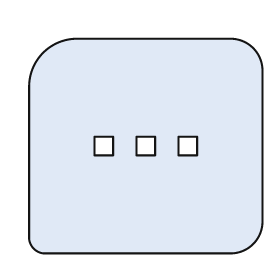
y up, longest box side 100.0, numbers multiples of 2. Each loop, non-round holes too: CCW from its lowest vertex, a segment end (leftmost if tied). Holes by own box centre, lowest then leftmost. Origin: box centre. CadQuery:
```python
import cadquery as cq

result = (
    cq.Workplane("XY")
    .moveTo(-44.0, -46.0)
    .lineTo(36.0, -46.0)
    .threePointArc((46.0, -42.0), (50.0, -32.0))
    .lineTo(50.0, 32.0)
    .threePointArc((46.0, 42.0), (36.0, 46.0))
    .lineTo(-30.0, 46.0)
    .threePointArc((-44.0, 40.0), (-50.0, 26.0))
    .lineTo(-50.0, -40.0)
    .threePointArc((-48.0, -44.0), (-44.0, -46.0))
    .close()
    .moveTo(-22.0, -4.0)
    .lineTo(-14.0, -4.0)
    .lineTo(-14.0, 4.0)
    .lineTo(-22.0, 4.0)
    .close()
    .moveTo(-4.0, -4.0)
    .lineTo(4.0, -4.0)
    .lineTo(4.0, 4.0)
    .lineTo(-4.0, 4.0)
    .close()
    .moveTo(14.0, -4.0)
    .lineTo(22.0, -4.0)
    .lineTo(22.0, 4.0)
    .lineTo(14.0, 4.0)
    .close()
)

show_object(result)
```